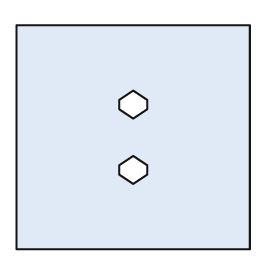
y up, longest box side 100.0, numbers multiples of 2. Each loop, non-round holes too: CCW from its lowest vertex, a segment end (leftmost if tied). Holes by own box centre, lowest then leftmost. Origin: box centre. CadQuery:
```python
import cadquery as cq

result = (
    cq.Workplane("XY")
    .moveTo(-50.0, -48.0)
    .lineTo(50.0, -48.0)
    .lineTo(50.0, 48.0)
    .lineTo(-50.0, 48.0)
    .close()
    .moveTo(0.0, -20.0)
    .lineTo(6.0, -16.0)
    .lineTo(6.0, -12.0)
    .lineTo(0.0, -8.0)
    .lineTo(-6.0, -12.0)
    .lineTo(-6.0, -16.0)
    .close()
    .moveTo(0.0, 8.0)
    .lineTo(6.0, 12.0)
    .lineTo(6.0, 16.0)
    .lineTo(0.0, 20.0)
    .lineTo(-6.0, 16.0)
    .lineTo(-6.0, 12.0)
    .close()
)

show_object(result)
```